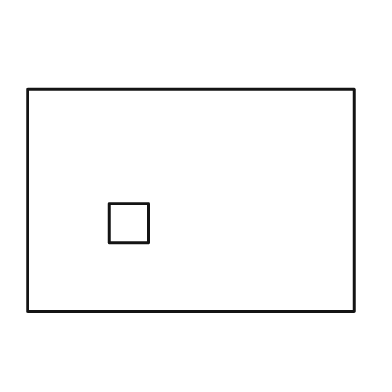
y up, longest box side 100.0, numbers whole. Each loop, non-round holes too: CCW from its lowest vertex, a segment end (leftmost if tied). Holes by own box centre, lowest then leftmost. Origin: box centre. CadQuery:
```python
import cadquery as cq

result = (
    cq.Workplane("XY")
    .moveTo(-50.0, -34.0)
    .lineTo(50.0, -34.0)
    .lineTo(50.0, 34.0)
    .lineTo(-50.0, 34.0)
    .close()
    .moveTo(-25.0, -13.0)
    .lineTo(-13.0, -13.0)
    .lineTo(-13.0, -1.0)
    .lineTo(-25.0, -1.0)
    .close()
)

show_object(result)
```